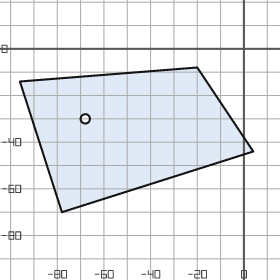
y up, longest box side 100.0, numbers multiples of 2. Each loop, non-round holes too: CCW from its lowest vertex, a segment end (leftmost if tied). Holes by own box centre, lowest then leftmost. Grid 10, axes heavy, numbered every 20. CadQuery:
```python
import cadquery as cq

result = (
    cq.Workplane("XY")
    .moveTo(-78.0, -70.0)
    .lineTo(4.0, -44.0)
    .lineTo(-20.0, -8.0)
    .lineTo(-96.0, -14.0)
    .close()
    .moveTo(-68.0, -30.0)
    .circle(2.0)
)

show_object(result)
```